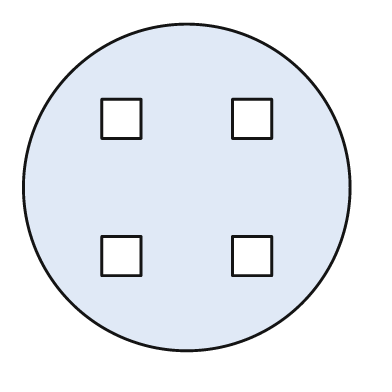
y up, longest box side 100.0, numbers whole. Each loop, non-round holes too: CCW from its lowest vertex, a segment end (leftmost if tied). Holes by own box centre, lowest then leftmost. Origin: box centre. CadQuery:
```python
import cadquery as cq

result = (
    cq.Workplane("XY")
    .moveTo(0.0, 0.0)
    .circle(50.0)
    .moveTo(-26.0, -27.0)
    .lineTo(-14.0, -27.0)
    .lineTo(-14.0, -15.0)
    .lineTo(-26.0, -15.0)
    .close()
    .moveTo(14.0, -27.0)
    .lineTo(26.0, -27.0)
    .lineTo(26.0, -15.0)
    .lineTo(14.0, -15.0)
    .close()
    .moveTo(-26.0, 15.0)
    .lineTo(-14.0, 15.0)
    .lineTo(-14.0, 27.0)
    .lineTo(-26.0, 27.0)
    .close()
    .moveTo(14.0, 15.0)
    .lineTo(26.0, 15.0)
    .lineTo(26.0, 27.0)
    .lineTo(14.0, 27.0)
    .close()
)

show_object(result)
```